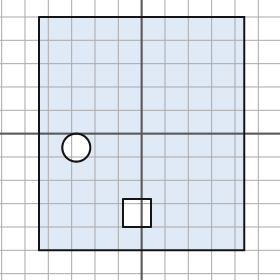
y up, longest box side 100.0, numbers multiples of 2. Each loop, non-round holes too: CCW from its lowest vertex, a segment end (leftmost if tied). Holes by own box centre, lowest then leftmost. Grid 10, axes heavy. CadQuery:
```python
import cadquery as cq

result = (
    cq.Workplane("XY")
    .moveTo(-44.0, -50.0)
    .lineTo(44.0, -50.0)
    .lineTo(44.0, 50.0)
    .lineTo(-44.0, 50.0)
    .close()
    .moveTo(-8.0, -40.0)
    .lineTo(4.0, -40.0)
    .lineTo(4.0, -28.0)
    .lineTo(-8.0, -28.0)
    .close()
    .moveTo(-28.0, -6.0)
    .circle(6.0)
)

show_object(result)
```